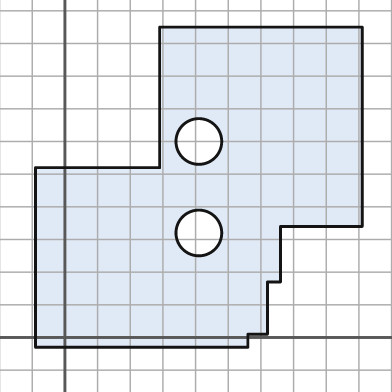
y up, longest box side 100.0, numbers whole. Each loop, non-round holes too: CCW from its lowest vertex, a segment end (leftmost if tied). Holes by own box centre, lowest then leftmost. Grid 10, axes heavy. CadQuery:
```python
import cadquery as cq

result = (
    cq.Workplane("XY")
    .moveTo(-9.0, -3.0)
    .lineTo(56.0, -3.0)
    .lineTo(56.0, 1.0)
    .lineTo(62.0, 1.0)
    .lineTo(62.0, 17.0)
    .lineTo(66.0, 17.0)
    .lineTo(66.0, 34.0)
    .lineTo(91.0, 34.0)
    .lineTo(91.0, 95.0)
    .lineTo(29.0, 95.0)
    .lineTo(29.0, 52.0)
    .lineTo(-9.0, 52.0)
    .close()
    .moveTo(41.0, 32.0)
    .circle(7.0)
    .moveTo(41.0, 60.0)
    .circle(7.0)
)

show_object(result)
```